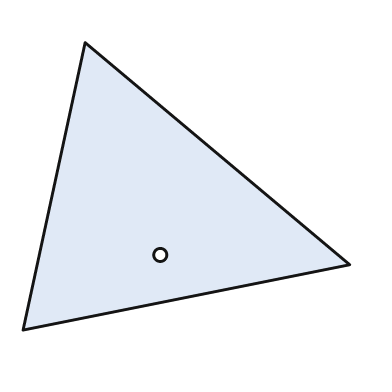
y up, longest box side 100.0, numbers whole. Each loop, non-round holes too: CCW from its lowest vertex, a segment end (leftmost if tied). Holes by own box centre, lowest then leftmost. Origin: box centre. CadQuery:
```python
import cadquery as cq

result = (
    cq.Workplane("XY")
    .moveTo(-50.0, -44.0)
    .lineTo(50.0, -24.0)
    .lineTo(-31.0, 44.0)
    .close()
    .moveTo(-8.0, -21.0)
    .circle(2.0)
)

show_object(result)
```